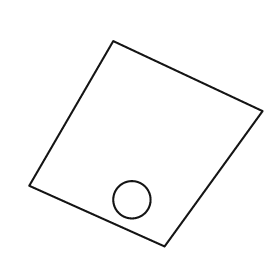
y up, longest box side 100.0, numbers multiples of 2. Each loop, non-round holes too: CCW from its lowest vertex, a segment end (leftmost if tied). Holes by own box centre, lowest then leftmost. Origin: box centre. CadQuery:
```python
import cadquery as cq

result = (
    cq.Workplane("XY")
    .moveTo(8.0, -44.0)
    .lineTo(50.0, 14.0)
    .lineTo(-14.0, 44.0)
    .lineTo(-50.0, -18.0)
    .close()
    .moveTo(-6.0, -24.0)
    .circle(8.0)
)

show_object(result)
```